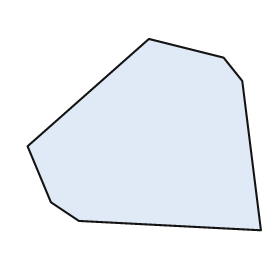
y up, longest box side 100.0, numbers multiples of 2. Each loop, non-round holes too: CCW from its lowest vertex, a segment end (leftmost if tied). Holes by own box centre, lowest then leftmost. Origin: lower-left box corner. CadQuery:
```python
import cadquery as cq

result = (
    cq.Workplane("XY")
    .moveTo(100.0, 0.0)
    .lineTo(92.0, 64.0)
    .lineTo(84.0, 74.0)
    .lineTo(52.0, 82.0)
    .lineTo(0.0, 36.0)
    .lineTo(10.0, 12.0)
    .lineTo(22.0, 4.0)
    .close()
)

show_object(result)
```